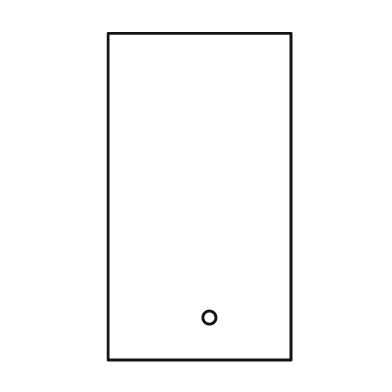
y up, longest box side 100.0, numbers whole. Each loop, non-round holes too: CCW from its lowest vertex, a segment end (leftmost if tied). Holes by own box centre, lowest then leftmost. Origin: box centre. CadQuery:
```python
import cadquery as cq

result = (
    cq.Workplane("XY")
    .moveTo(-28.0, -50.0)
    .lineTo(28.0, -50.0)
    .lineTo(28.0, 50.0)
    .lineTo(-28.0, 50.0)
    .close()
    .moveTo(3.0, -37.0)
    .circle(2.0)
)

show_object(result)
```